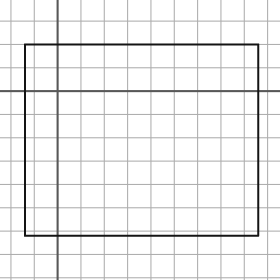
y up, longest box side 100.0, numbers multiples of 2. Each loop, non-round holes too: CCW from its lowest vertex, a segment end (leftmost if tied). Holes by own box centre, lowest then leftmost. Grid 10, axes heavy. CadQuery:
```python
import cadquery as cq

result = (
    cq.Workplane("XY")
    .moveTo(-14.0, -62.0)
    .lineTo(86.0, -62.0)
    .lineTo(86.0, 20.0)
    .lineTo(-14.0, 20.0)
    .close()
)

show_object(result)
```